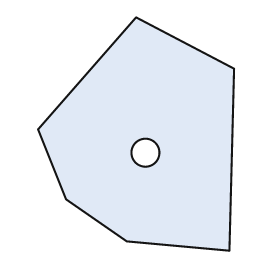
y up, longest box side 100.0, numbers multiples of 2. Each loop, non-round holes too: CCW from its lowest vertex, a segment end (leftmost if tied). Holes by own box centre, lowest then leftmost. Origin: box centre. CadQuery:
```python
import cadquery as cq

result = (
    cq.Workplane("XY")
    .moveTo(40.0, -50.0)
    .lineTo(42.0, 28.0)
    .lineTo(0.0, 50.0)
    .lineTo(-42.0, 2.0)
    .lineTo(-30.0, -28.0)
    .lineTo(-4.0, -46.0)
    .close()
    .moveTo(4.0, -8.0)
    .circle(6.0)
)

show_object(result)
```